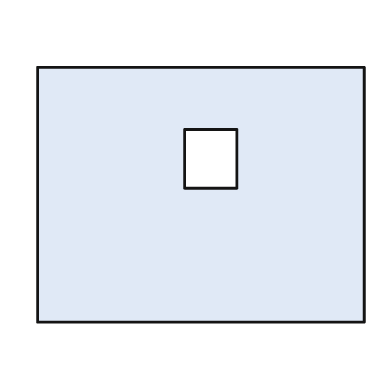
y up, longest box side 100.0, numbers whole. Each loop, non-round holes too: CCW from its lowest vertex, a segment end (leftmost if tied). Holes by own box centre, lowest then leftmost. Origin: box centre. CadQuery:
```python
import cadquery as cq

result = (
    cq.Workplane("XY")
    .moveTo(-50.0, -39.0)
    .lineTo(50.0, -39.0)
    .lineTo(50.0, 39.0)
    .lineTo(-50.0, 39.0)
    .close()
    .moveTo(-5.0, 2.0)
    .lineTo(11.0, 2.0)
    .lineTo(11.0, 20.0)
    .lineTo(-5.0, 20.0)
    .close()
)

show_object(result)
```